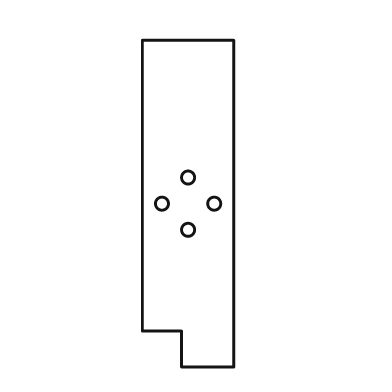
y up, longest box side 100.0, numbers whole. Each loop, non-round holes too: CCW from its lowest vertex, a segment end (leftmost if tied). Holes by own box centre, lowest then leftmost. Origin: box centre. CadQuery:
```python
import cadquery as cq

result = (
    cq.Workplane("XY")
    .moveTo(-2.0, -50.0)
    .lineTo(14.0, -50.0)
    .lineTo(14.0, 50.0)
    .lineTo(-14.0, 50.0)
    .lineTo(-14.0, -39.0)
    .lineTo(-2.0, -39.0)
    .close()
    .moveTo(0.0, -8.0)
    .circle(2.0)
    .moveTo(-8.0, 0.0)
    .circle(2.0)
    .moveTo(8.0, 0.0)
    .circle(2.0)
    .moveTo(0.0, 8.0)
    .circle(2.0)
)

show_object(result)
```